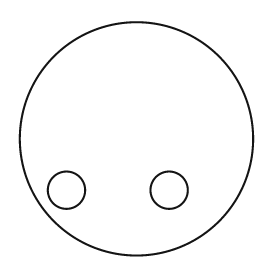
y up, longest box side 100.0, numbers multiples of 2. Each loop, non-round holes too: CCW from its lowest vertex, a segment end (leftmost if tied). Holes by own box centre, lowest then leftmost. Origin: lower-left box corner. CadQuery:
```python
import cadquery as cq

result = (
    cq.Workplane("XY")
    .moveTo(50.0, 50.0)
    .circle(50.0)
    .moveTo(20.0, 28.0)
    .circle(8.0)
    .moveTo(64.0, 28.0)
    .circle(8.0)
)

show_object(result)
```